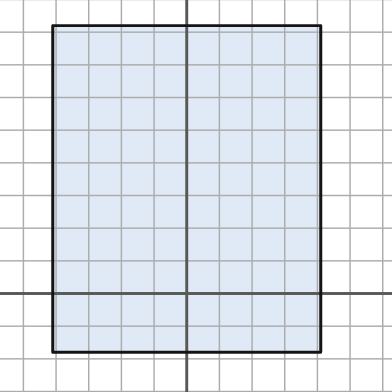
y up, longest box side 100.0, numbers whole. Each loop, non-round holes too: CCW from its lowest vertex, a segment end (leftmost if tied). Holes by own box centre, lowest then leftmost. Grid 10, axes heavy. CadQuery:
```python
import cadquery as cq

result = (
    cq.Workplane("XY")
    .moveTo(-41.0, -18.0)
    .lineTo(41.0, -18.0)
    .lineTo(41.0, 82.0)
    .lineTo(-41.0, 82.0)
    .close()
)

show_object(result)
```